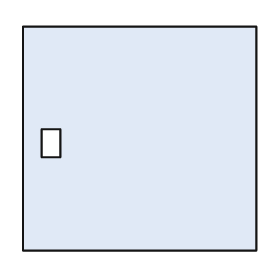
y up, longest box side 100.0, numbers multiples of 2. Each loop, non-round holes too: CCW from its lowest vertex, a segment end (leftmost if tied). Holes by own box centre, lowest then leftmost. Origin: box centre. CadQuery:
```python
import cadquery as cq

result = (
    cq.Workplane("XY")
    .moveTo(-50.0, -48.0)
    .lineTo(50.0, -48.0)
    .lineTo(50.0, 48.0)
    .lineTo(-50.0, 48.0)
    .close()
    .moveTo(-42.0, -8.0)
    .lineTo(-34.0, -8.0)
    .lineTo(-34.0, 4.0)
    .lineTo(-42.0, 4.0)
    .close()
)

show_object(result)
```